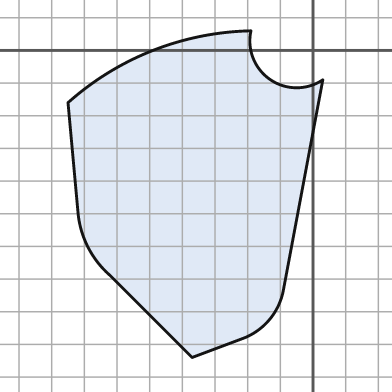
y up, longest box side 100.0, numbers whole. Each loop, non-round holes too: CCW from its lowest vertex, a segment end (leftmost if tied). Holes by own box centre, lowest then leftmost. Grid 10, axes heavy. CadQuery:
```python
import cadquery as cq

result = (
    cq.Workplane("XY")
    .moveTo(-37.0, -94.0)
    .lineTo(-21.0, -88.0)
    .threePointArc((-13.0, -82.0), (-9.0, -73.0))
    .lineTo(3.0, -9.0)
    .threePointArc((-13.0, -9.0), (-19.0, 6.0))
    .threePointArc((-49.0, 0.0), (-75.0, -16.0))
    .lineTo(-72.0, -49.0)
    .threePointArc((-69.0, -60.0), (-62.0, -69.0))
    .close()
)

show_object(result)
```